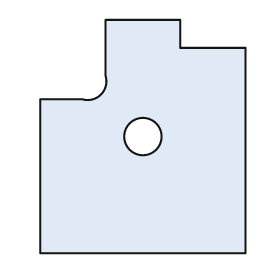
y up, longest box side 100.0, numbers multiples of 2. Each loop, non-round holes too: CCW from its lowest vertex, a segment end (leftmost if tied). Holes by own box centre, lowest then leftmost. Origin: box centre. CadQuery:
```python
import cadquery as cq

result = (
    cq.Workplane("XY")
    .moveTo(-44.0, -50.0)
    .lineTo(44.0, -50.0)
    .lineTo(44.0, 38.0)
    .lineTo(16.0, 38.0)
    .lineTo(16.0, 50.0)
    .lineTo(-16.0, 50.0)
    .lineTo(-16.0, 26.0)
    .threePointArc((-18.0, 18.0), (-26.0, 16.0))
    .lineTo(-44.0, 16.0)
    .close()
    .moveTo(0.0, 0.0)
    .circle(8.0)
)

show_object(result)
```